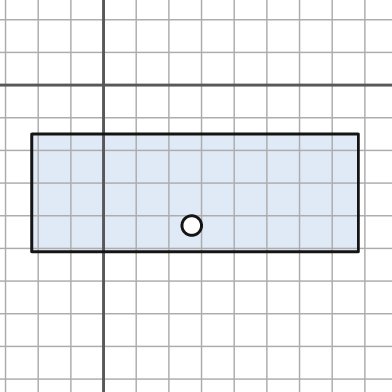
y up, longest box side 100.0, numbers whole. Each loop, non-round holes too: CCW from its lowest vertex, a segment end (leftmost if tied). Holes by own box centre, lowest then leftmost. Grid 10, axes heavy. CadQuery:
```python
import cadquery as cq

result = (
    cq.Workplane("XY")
    .moveTo(-22.0, -51.0)
    .lineTo(78.0, -51.0)
    .lineTo(78.0, -15.0)
    .lineTo(-22.0, -15.0)
    .close()
    .moveTo(27.0, -43.0)
    .circle(3.0)
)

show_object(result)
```